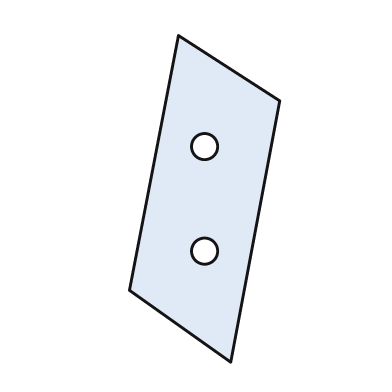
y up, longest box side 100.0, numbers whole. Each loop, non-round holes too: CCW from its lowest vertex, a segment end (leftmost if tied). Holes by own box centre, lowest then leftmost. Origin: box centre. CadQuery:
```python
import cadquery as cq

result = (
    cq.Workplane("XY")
    .moveTo(8.0, -50.0)
    .lineTo(23.0, 30.0)
    .lineTo(-8.0, 50.0)
    .lineTo(-23.0, -28.0)
    .close()
    .moveTo(0.0, -16.0)
    .circle(4.0)
    .moveTo(0.0, 16.0)
    .circle(4.0)
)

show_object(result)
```